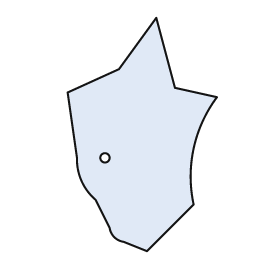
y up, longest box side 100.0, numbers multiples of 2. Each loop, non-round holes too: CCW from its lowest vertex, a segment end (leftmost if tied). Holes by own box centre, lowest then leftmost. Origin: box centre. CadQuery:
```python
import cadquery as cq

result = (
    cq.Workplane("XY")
    .moveTo(2.0, -50.0)
    .lineTo(22.0, -30.0)
    .threePointArc((22.0, -6.0), (32.0, 16.0))
    .lineTo(14.0, 20.0)
    .lineTo(6.0, 50.0)
    .lineTo(-10.0, 28.0)
    .lineTo(-32.0, 18.0)
    .lineTo(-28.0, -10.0)
    .threePointArc((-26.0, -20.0), (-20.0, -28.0))
    .lineTo(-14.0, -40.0)
    .threePointArc((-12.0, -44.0), (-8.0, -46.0))
    .close()
    .moveTo(-16.0, -10.0)
    .circle(2.0)
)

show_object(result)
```